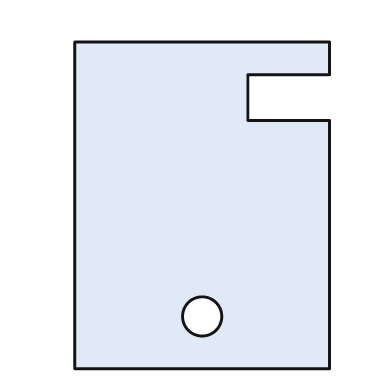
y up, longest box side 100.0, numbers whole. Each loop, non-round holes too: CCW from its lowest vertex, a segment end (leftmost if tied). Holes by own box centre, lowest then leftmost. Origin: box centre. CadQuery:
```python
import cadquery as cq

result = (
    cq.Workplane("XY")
    .moveTo(-39.0, -50.0)
    .lineTo(39.0, -50.0)
    .lineTo(39.0, 26.0)
    .lineTo(14.0, 26.0)
    .lineTo(14.0, 40.0)
    .lineTo(39.0, 40.0)
    .lineTo(39.0, 50.0)
    .lineTo(-39.0, 50.0)
    .close()
    .moveTo(0.0, -34.0)
    .circle(6.0)
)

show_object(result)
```